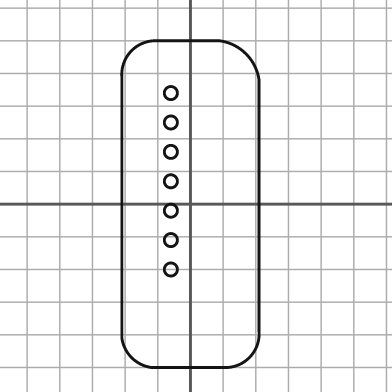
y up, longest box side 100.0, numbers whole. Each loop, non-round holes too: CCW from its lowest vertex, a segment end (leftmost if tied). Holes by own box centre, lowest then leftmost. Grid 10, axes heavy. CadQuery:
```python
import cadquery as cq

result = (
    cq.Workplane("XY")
    .moveTo(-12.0, -50.0)
    .lineTo(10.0, -50.0)
    .threePointArc((18.0, -47.0), (21.0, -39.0))
    .lineTo(21.0, 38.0)
    .threePointArc((17.0, 46.0), (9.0, 50.0))
    .lineTo(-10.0, 50.0)
    .threePointArc((-18.0, 47.0), (-21.0, 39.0))
    .lineTo(-21.0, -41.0)
    .threePointArc((-18.0, -47.0), (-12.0, -50.0))
    .close()
    .moveTo(-6.0, -20.0)
    .circle(2.0)
    .moveTo(-6.0, -11.0)
    .circle(2.0)
    .moveTo(-6.0, -2.0)
    .circle(2.0)
    .moveTo(-6.0, 7.0)
    .circle(2.0)
    .moveTo(-6.0, 16.0)
    .circle(2.0)
    .moveTo(-6.0, 25.0)
    .circle(2.0)
    .moveTo(-6.0, 34.0)
    .circle(2.0)
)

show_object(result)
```